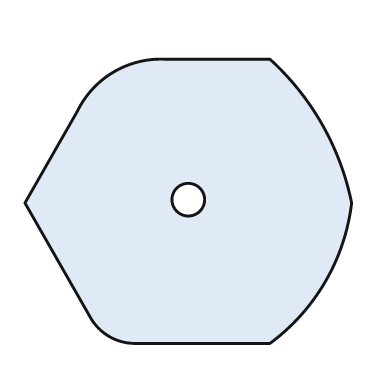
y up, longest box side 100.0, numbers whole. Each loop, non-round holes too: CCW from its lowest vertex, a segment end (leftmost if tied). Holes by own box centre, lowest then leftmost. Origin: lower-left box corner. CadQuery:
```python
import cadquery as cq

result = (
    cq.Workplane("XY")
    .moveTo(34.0, 0.0)
    .lineTo(75.0, 0.0)
    .threePointArc((92.0, 19.0), (100.0, 43.0))
    .threePointArc((91.0, 67.0), (75.0, 87.0))
    .lineTo(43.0, 87.0)
    .threePointArc((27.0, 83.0), (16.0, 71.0))
    .lineTo(0.0, 43.0)
    .lineTo(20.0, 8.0)
    .threePointArc((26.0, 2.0), (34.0, 0.0))
    .close()
    .moveTo(50.0, 44.0)
    .circle(5.0)
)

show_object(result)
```